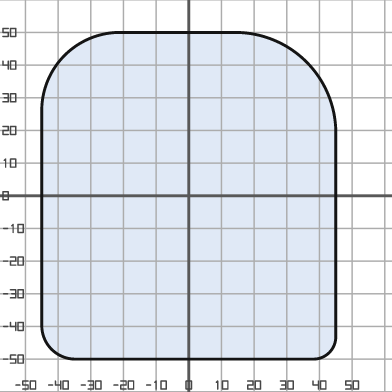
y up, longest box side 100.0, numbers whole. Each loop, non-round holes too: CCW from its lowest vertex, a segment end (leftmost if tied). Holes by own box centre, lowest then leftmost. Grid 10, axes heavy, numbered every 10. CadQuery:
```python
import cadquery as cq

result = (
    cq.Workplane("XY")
    .moveTo(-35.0, -50.0)
    .lineTo(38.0, -50.0)
    .threePointArc((43.0, -48.0), (45.0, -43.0))
    .lineTo(45.0, 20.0)
    .threePointArc((36.0, 41.0), (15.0, 50.0))
    .lineTo(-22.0, 50.0)
    .threePointArc((-38.0, 43.0), (-45.0, 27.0))
    .lineTo(-45.0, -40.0)
    .threePointArc((-42.0, -47.0), (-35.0, -50.0))
    .close()
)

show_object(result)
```